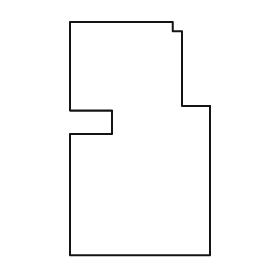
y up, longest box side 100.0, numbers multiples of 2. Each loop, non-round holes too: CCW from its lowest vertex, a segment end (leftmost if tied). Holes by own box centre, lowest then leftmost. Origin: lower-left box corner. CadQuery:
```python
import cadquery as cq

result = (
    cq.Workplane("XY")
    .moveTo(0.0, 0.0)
    .lineTo(60.0, 0.0)
    .lineTo(60.0, 64.0)
    .lineTo(48.0, 64.0)
    .lineTo(48.0, 96.0)
    .lineTo(44.0, 96.0)
    .lineTo(44.0, 100.0)
    .lineTo(0.0, 100.0)
    .lineTo(0.0, 62.0)
    .lineTo(18.0, 62.0)
    .lineTo(18.0, 52.0)
    .lineTo(0.0, 52.0)
    .close()
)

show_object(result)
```